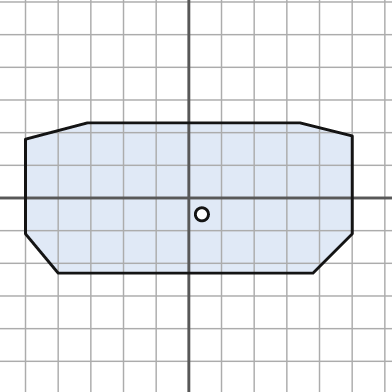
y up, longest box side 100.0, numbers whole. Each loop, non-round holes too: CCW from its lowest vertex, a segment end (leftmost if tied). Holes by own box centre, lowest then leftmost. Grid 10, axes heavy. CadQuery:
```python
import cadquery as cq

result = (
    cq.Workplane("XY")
    .moveTo(-40.0, -23.0)
    .lineTo(38.0, -23.0)
    .lineTo(50.0, -11.0)
    .lineTo(50.0, 19.0)
    .lineTo(34.0, 23.0)
    .lineTo(-31.0, 23.0)
    .lineTo(-50.0, 18.0)
    .lineTo(-50.0, -11.0)
    .close()
    .moveTo(4.0, -5.0)
    .circle(2.0)
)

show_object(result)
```